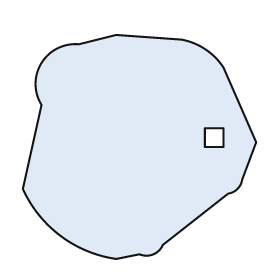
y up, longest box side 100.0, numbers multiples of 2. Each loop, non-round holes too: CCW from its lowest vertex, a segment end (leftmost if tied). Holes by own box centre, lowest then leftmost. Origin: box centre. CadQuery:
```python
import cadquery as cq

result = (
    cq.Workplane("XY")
    .moveTo(-10.0, -48.0)
    .lineTo(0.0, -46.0)
    .threePointArc((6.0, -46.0), (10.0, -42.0))
    .lineTo(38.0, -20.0)
    .threePointArc((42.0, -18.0), (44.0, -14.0))
    .lineTo(50.0, 2.0)
    .lineTo(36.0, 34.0)
    .threePointArc((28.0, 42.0), (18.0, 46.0))
    .lineTo(-10.0, 48.0)
    .lineTo(-26.0, 44.0)
    .threePointArc((-42.0, 36.0), (-42.0, 18.0))
    .lineTo(-50.0, -18.0)
    .threePointArc((-34.0, -38.0), (-10.0, -48.0))
    .close()
    .moveTo(28.0, 0.0)
    .lineTo(36.0, 0.0)
    .lineTo(36.0, 8.0)
    .lineTo(28.0, 8.0)
    .close()
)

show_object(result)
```